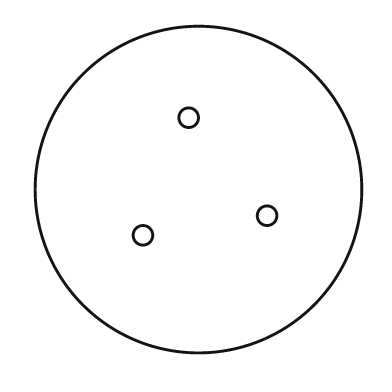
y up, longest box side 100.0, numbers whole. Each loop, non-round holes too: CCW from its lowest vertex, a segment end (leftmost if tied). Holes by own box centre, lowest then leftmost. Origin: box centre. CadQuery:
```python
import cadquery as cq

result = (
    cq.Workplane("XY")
    .moveTo(0.0, 0.0)
    .circle(50.0)
    .moveTo(-17.0, -14.0)
    .circle(3.0)
    .moveTo(21.0, -8.0)
    .circle(3.0)
    .moveTo(-3.0, 22.0)
    .circle(3.0)
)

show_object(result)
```